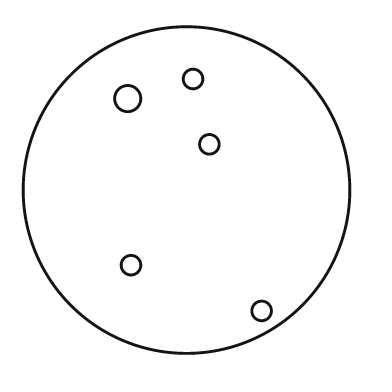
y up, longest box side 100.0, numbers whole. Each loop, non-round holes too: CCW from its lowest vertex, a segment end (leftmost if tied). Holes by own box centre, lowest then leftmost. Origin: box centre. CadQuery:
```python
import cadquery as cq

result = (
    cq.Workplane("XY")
    .moveTo(0.0, 0.0)
    .circle(50.0)
    .moveTo(23.0, -37.0)
    .circle(3.0)
    .moveTo(-17.0, -23.0)
    .circle(3.0)
    .moveTo(7.0, 14.0)
    .circle(3.0)
    .moveTo(-18.0, 28.0)
    .circle(4.0)
    .moveTo(2.0, 34.0)
    .circle(3.0)
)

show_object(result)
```